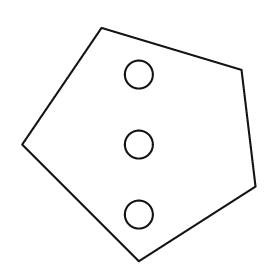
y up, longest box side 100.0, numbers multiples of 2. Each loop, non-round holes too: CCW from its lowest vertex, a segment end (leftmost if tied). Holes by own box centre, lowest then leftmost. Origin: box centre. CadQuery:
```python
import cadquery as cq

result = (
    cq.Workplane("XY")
    .moveTo(0.0, -50.0)
    .lineTo(50.0, -18.0)
    .lineTo(44.0, 32.0)
    .lineTo(-16.0, 50.0)
    .lineTo(-50.0, 0.0)
    .close()
    .moveTo(0.0, -30.0)
    .circle(6.0)
    .moveTo(0.0, 0.0)
    .circle(6.0)
    .moveTo(0.0, 30.0)
    .circle(6.0)
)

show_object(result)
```